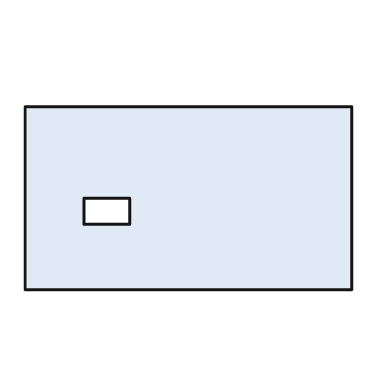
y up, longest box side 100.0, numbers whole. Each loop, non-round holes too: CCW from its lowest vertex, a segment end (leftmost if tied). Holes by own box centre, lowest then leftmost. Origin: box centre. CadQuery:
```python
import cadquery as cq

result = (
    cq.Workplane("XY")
    .moveTo(-50.0, -28.0)
    .lineTo(50.0, -28.0)
    .lineTo(50.0, 28.0)
    .lineTo(-50.0, 28.0)
    .close()
    .moveTo(-32.0, -8.0)
    .lineTo(-18.0, -8.0)
    .lineTo(-18.0, 0.0)
    .lineTo(-32.0, 0.0)
    .close()
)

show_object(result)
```